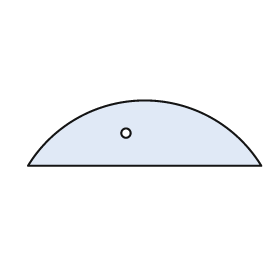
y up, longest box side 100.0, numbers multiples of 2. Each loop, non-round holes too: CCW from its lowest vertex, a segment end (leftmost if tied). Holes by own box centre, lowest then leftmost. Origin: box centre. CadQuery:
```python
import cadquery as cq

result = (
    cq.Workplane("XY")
    .moveTo(-50.0, -14.0)
    .lineTo(50.0, -14.0)
    .threePointArc((0.0, 14.0), (-50.0, -14.0))
    .close()
    .moveTo(-8.0, 0.0)
    .circle(2.0)
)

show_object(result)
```